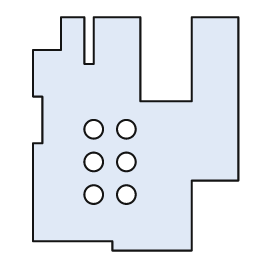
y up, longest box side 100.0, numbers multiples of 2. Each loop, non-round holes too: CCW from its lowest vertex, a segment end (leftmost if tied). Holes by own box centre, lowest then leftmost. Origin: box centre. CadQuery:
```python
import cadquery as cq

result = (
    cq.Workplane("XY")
    .moveTo(-10.0, -50.0)
    .lineTo(24.0, -50.0)
    .lineTo(24.0, -20.0)
    .lineTo(44.0, -20.0)
    .lineTo(44.0, 50.0)
    .lineTo(24.0, 50.0)
    .lineTo(24.0, 14.0)
    .lineTo(2.0, 14.0)
    .lineTo(2.0, 50.0)
    .lineTo(-18.0, 50.0)
    .lineTo(-18.0, 30.0)
    .lineTo(-22.0, 30.0)
    .lineTo(-22.0, 50.0)
    .lineTo(-32.0, 50.0)
    .lineTo(-32.0, 36.0)
    .lineTo(-44.0, 36.0)
    .lineTo(-44.0, 16.0)
    .lineTo(-40.0, 16.0)
    .lineTo(-40.0, -4.0)
    .lineTo(-44.0, -4.0)
    .lineTo(-44.0, -46.0)
    .lineTo(-10.0, -46.0)
    .close()
    .moveTo(-18.0, -26.0)
    .circle(4.0)
    .moveTo(-4.0, -26.0)
    .circle(4.0)
    .moveTo(-18.0, -12.0)
    .circle(4.0)
    .moveTo(-4.0, -12.0)
    .circle(4.0)
    .moveTo(-18.0, 2.0)
    .circle(4.0)
    .moveTo(-4.0, 2.0)
    .circle(4.0)
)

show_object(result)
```